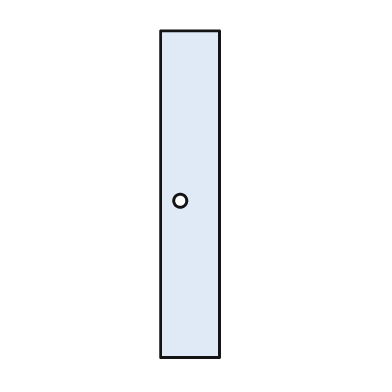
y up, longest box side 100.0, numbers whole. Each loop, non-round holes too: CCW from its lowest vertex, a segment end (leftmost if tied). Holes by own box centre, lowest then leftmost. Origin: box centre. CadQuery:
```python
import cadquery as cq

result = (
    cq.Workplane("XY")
    .moveTo(-9.0, -50.0)
    .lineTo(9.0, -50.0)
    .lineTo(9.0, 50.0)
    .lineTo(-9.0, 50.0)
    .close()
    .moveTo(-3.0, -2.0)
    .circle(2.0)
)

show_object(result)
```